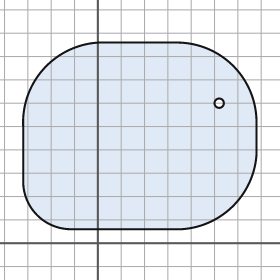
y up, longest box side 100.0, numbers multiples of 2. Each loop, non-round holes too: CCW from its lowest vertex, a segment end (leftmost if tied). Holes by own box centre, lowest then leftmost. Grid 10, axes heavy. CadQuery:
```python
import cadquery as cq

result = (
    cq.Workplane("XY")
    .moveTo(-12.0, 6.0)
    .lineTo(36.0, 6.0)
    .threePointArc((58.0, 16.0), (68.0, 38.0))
    .lineTo(68.0, 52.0)
    .threePointArc((58.0, 76.0), (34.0, 86.0))
    .lineTo(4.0, 86.0)
    .threePointArc((-22.0, 76.0), (-32.0, 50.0))
    .lineTo(-32.0, 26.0)
    .threePointArc((-26.0, 12.0), (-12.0, 6.0))
    .close()
    .moveTo(52.0, 60.0)
    .circle(2.0)
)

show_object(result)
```